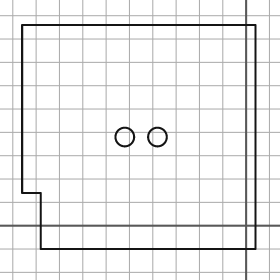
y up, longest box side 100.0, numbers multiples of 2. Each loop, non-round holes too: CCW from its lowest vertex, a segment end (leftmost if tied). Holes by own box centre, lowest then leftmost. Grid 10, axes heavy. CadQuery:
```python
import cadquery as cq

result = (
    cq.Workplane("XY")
    .moveTo(-88.0, -10.0)
    .lineTo(4.0, -10.0)
    .lineTo(4.0, 86.0)
    .lineTo(-96.0, 86.0)
    .lineTo(-96.0, 14.0)
    .lineTo(-88.0, 14.0)
    .close()
    .moveTo(-52.0, 38.0)
    .circle(4.0)
    .moveTo(-38.0, 38.0)
    .circle(4.0)
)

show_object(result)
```